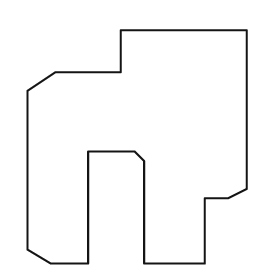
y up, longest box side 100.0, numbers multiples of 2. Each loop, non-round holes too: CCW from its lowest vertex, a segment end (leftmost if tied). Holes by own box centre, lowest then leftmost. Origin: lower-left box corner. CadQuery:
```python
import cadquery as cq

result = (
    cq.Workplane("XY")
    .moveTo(10.0, 0.0)
    .lineTo(26.0, 0.0)
    .lineTo(26.0, 48.0)
    .lineTo(46.0, 48.0)
    .lineTo(50.0, 44.0)
    .lineTo(50.0, 0.0)
    .lineTo(76.0, 0.0)
    .lineTo(76.0, 28.0)
    .lineTo(86.0, 28.0)
    .lineTo(94.0, 32.0)
    .lineTo(94.0, 100.0)
    .lineTo(40.0, 100.0)
    .lineTo(40.0, 82.0)
    .lineTo(12.0, 82.0)
    .lineTo(0.0, 74.0)
    .lineTo(0.0, 6.0)
    .close()
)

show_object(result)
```